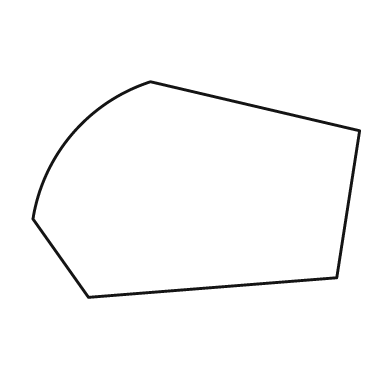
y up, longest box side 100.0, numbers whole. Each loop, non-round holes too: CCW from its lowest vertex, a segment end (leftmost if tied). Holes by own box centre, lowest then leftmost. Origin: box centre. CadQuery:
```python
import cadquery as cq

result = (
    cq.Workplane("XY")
    .moveTo(-33.0, -33.0)
    .lineTo(43.0, -27.0)
    .lineTo(50.0, 18.0)
    .lineTo(-14.0, 33.0)
    .threePointArc((-38.0, 17.0), (-50.0, -9.0))
    .close()
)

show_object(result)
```